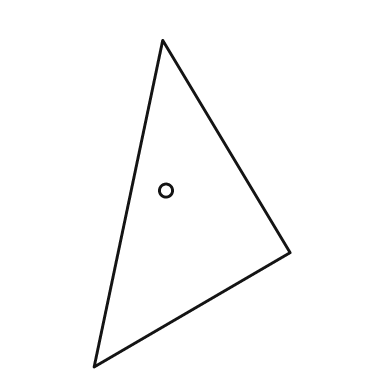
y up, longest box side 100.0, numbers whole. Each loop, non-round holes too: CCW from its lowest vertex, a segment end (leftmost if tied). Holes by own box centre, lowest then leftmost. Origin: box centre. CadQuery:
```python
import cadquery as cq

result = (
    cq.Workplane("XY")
    .moveTo(-30.0, -50.0)
    .lineTo(30.0, -15.0)
    .lineTo(-9.0, 50.0)
    .close()
    .moveTo(-8.0, 4.0)
    .circle(2.0)
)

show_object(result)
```